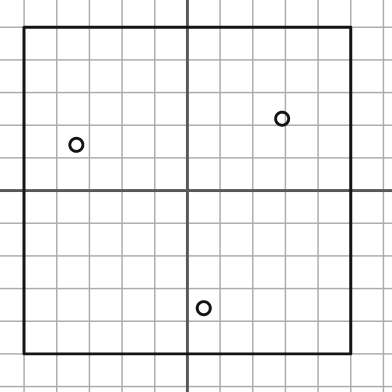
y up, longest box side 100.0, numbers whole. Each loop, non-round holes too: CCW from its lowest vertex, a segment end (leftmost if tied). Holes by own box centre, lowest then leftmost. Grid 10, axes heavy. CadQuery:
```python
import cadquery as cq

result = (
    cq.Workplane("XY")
    .moveTo(-50.0, -50.0)
    .lineTo(50.0, -50.0)
    .lineTo(50.0, 50.0)
    .lineTo(-50.0, 50.0)
    .close()
    .moveTo(5.0, -36.0)
    .circle(2.0)
    .moveTo(-34.0, 14.0)
    .circle(2.0)
    .moveTo(29.0, 22.0)
    .circle(2.0)
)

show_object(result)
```